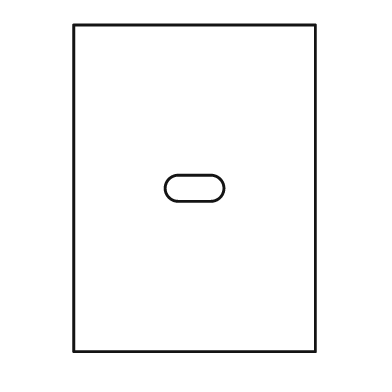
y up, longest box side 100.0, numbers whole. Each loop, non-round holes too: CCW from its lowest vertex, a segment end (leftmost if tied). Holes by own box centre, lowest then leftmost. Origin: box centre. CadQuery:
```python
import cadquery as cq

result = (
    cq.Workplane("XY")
    .moveTo(-37.0, -50.0)
    .lineTo(37.0, -50.0)
    .lineTo(37.0, 50.0)
    .lineTo(-37.0, 50.0)
    .close()
    .moveTo(-5.0, -4.0)
    .lineTo(5.0, -4.0)
    .threePointArc((9.0, 0.0), (5.0, 4.0))
    .lineTo(-5.0, 4.0)
    .threePointArc((-9.0, 0.0), (-5.0, -4.0))
    .close()
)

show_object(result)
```